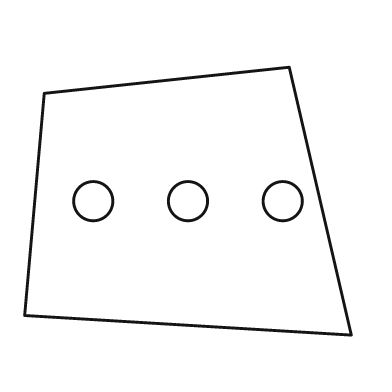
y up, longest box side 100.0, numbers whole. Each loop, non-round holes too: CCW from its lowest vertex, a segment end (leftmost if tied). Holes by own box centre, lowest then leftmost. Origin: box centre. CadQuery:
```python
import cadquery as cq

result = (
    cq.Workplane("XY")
    .moveTo(50.0, -41.0)
    .lineTo(31.0, 41.0)
    .lineTo(-44.0, 33.0)
    .lineTo(-50.0, -35.0)
    .close()
    .moveTo(-29.0, 0.0)
    .circle(6.0)
    .moveTo(0.0, 0.0)
    .circle(6.0)
    .moveTo(29.0, 0.0)
    .circle(6.0)
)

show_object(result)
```